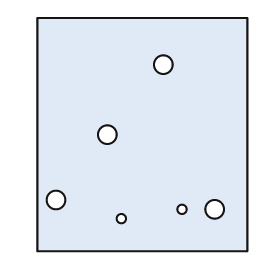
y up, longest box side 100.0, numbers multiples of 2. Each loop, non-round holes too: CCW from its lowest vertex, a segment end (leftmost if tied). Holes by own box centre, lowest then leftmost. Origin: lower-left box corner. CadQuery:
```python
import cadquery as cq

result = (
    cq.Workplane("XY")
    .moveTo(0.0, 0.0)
    .lineTo(90.0, 0.0)
    .lineTo(90.0, 100.0)
    .lineTo(0.0, 100.0)
    .close()
    .moveTo(36.0, 14.0)
    .circle(2.0)
    .moveTo(62.0, 18.0)
    .circle(2.0)
    .moveTo(76.0, 18.0)
    .circle(4.0)
    .moveTo(8.0, 22.0)
    .circle(4.0)
    .moveTo(30.0, 50.0)
    .circle(4.0)
    .moveTo(54.0, 80.0)
    .circle(4.0)
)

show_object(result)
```